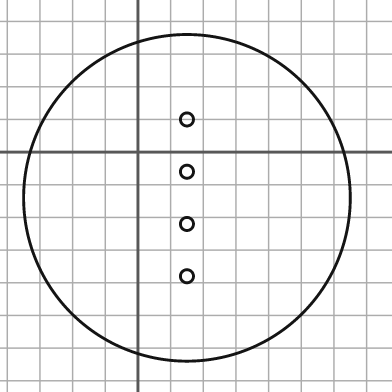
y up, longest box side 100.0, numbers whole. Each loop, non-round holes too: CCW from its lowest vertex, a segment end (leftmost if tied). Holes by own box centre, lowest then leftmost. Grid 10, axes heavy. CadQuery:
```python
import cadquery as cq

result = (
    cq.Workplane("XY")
    .moveTo(15.0, -14.0)
    .circle(50.0)
    .moveTo(15.0, -38.0)
    .circle(2.0)
    .moveTo(15.0, -22.0)
    .circle(2.0)
    .moveTo(15.0, -6.0)
    .circle(2.0)
    .moveTo(15.0, 10.0)
    .circle(2.0)
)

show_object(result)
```